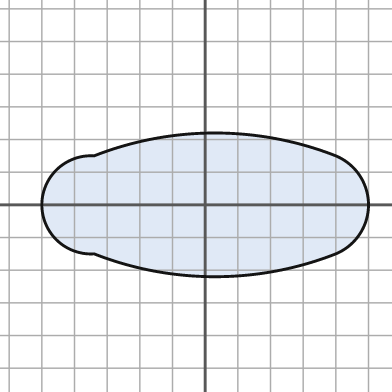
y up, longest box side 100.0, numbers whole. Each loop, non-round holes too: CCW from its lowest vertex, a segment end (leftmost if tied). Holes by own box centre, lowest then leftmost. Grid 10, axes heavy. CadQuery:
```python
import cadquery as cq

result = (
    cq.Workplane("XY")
    .moveTo(-34.0, -15.0)
    .threePointArc((3.0, -22.0), (40.0, -15.0))
    .threePointArc((50.0, 0.0), (40.0, 15.0))
    .threePointArc((3.0, 22.0), (-34.0, 15.0))
    .threePointArc((-50.0, 0.0), (-34.0, -15.0))
    .close()
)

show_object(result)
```